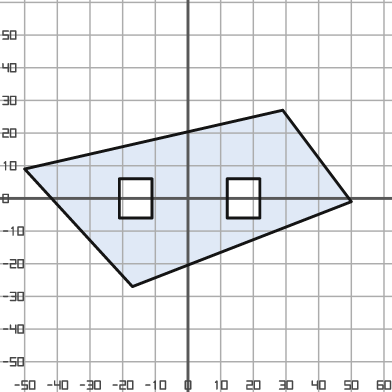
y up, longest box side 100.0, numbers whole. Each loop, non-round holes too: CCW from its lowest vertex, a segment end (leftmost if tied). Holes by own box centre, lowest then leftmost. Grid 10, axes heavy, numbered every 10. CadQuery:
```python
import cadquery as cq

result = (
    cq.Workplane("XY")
    .moveTo(-17.0, -27.0)
    .lineTo(50.0, -1.0)
    .lineTo(29.0, 27.0)
    .lineTo(-50.0, 9.0)
    .close()
    .moveTo(-21.0, -6.0)
    .lineTo(-11.0, -6.0)
    .lineTo(-11.0, 6.0)
    .lineTo(-21.0, 6.0)
    .close()
    .moveTo(12.0, -6.0)
    .lineTo(22.0, -6.0)
    .lineTo(22.0, 6.0)
    .lineTo(12.0, 6.0)
    .close()
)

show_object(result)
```